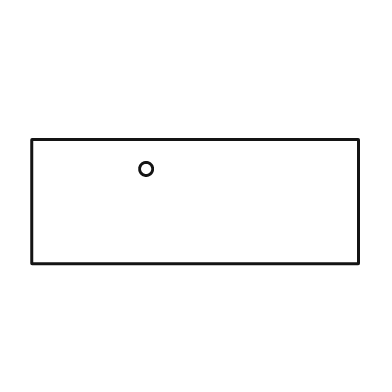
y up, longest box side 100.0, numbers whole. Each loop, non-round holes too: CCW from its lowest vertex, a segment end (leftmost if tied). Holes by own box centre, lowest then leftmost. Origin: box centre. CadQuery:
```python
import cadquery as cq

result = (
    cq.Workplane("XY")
    .moveTo(-50.0, -19.0)
    .lineTo(50.0, -19.0)
    .lineTo(50.0, 19.0)
    .lineTo(-50.0, 19.0)
    .close()
    .moveTo(-15.0, 10.0)
    .circle(2.0)
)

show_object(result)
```